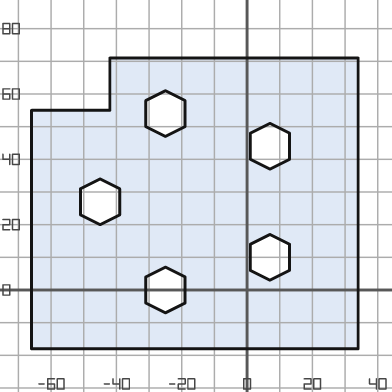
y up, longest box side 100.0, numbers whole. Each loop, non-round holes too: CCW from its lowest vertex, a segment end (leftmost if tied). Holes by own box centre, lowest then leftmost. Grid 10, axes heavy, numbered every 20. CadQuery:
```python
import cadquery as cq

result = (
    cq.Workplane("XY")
    .moveTo(-66.0, -18.0)
    .lineTo(34.0, -18.0)
    .lineTo(34.0, 71.0)
    .lineTo(-42.0, 71.0)
    .lineTo(-42.0, 55.0)
    .lineTo(-66.0, 55.0)
    .close()
    .moveTo(-25.0, -7.0)
    .lineTo(-19.0, -4.0)
    .lineTo(-19.0, 4.0)
    .lineTo(-25.0, 7.0)
    .lineTo(-31.0, 4.0)
    .lineTo(-31.0, -4.0)
    .close()
    .moveTo(7.0, 3.0)
    .lineTo(13.0, 6.0)
    .lineTo(13.0, 14.0)
    .lineTo(7.0, 17.0)
    .lineTo(1.0, 14.0)
    .lineTo(1.0, 6.0)
    .close()
    .moveTo(-45.0, 20.0)
    .lineTo(-39.0, 23.0)
    .lineTo(-39.0, 31.0)
    .lineTo(-45.0, 34.0)
    .lineTo(-51.0, 31.0)
    .lineTo(-51.0, 23.0)
    .close()
    .moveTo(7.0, 37.0)
    .lineTo(13.0, 40.0)
    .lineTo(13.0, 48.0)
    .lineTo(7.0, 51.0)
    .lineTo(1.0, 48.0)
    .lineTo(1.0, 40.0)
    .close()
    .moveTo(-25.0, 47.0)
    .lineTo(-19.0, 50.0)
    .lineTo(-19.0, 58.0)
    .lineTo(-25.0, 61.0)
    .lineTo(-31.0, 58.0)
    .lineTo(-31.0, 50.0)
    .close()
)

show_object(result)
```